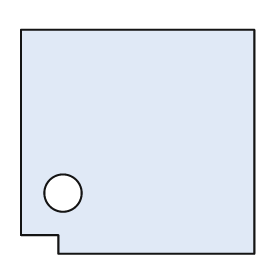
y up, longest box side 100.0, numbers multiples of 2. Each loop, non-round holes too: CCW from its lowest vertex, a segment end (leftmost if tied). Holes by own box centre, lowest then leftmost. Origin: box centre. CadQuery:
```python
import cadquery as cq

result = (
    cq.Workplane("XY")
    .moveTo(-34.0, -48.0)
    .lineTo(50.0, -48.0)
    .lineTo(50.0, 48.0)
    .lineTo(-50.0, 48.0)
    .lineTo(-50.0, -40.0)
    .lineTo(-34.0, -40.0)
    .close()
    .moveTo(-32.0, -22.0)
    .circle(8.0)
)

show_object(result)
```